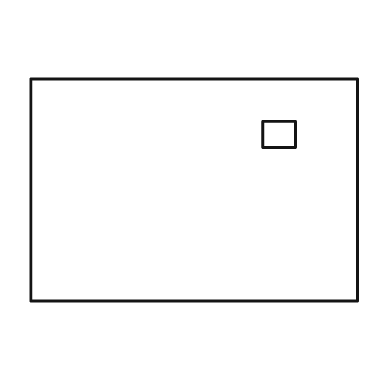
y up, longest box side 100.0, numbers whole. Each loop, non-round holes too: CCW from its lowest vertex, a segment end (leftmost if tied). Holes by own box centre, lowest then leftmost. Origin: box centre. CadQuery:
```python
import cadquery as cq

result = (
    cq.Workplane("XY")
    .moveTo(-50.0, -34.0)
    .lineTo(50.0, -34.0)
    .lineTo(50.0, 34.0)
    .lineTo(-50.0, 34.0)
    .close()
    .moveTo(21.0, 13.0)
    .lineTo(31.0, 13.0)
    .lineTo(31.0, 21.0)
    .lineTo(21.0, 21.0)
    .close()
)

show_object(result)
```